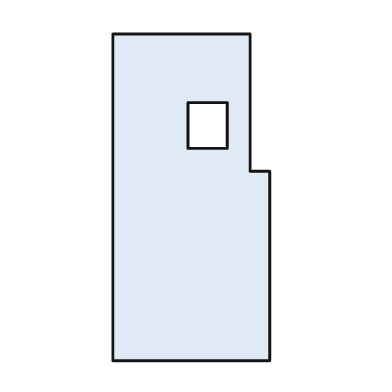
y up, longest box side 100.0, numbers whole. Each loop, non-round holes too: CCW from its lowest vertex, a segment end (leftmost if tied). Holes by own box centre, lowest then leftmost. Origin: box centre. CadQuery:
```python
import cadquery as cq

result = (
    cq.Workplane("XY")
    .moveTo(-24.0, -50.0)
    .lineTo(24.0, -50.0)
    .lineTo(24.0, 8.0)
    .lineTo(18.0, 8.0)
    .lineTo(18.0, 50.0)
    .lineTo(-24.0, 50.0)
    .close()
    .moveTo(-1.0, 15.0)
    .lineTo(11.0, 15.0)
    .lineTo(11.0, 29.0)
    .lineTo(-1.0, 29.0)
    .close()
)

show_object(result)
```